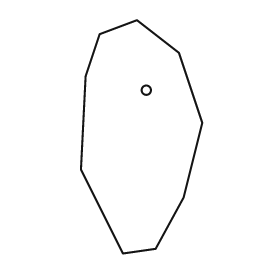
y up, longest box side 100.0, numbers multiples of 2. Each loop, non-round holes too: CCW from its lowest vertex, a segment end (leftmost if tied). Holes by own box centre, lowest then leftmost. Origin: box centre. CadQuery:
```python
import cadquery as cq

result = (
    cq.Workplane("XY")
    .moveTo(-8.0, -50.0)
    .lineTo(6.0, -48.0)
    .lineTo(18.0, -26.0)
    .lineTo(26.0, 6.0)
    .lineTo(16.0, 36.0)
    .lineTo(-2.0, 50.0)
    .lineTo(-18.0, 44.0)
    .lineTo(-24.0, 26.0)
    .lineTo(-26.0, -14.0)
    .close()
    .moveTo(2.0, 20.0)
    .circle(2.0)
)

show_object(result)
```